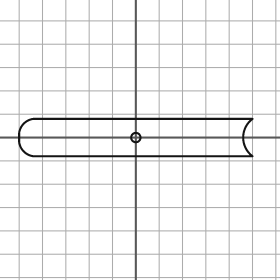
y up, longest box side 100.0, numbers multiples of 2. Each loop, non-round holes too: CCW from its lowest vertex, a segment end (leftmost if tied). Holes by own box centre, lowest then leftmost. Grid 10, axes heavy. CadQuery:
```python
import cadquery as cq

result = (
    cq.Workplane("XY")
    .moveTo(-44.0, -8.0)
    .lineTo(50.0, -8.0)
    .threePointArc((46.0, 0.0), (50.0, 8.0))
    .lineTo(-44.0, 8.0)
    .threePointArc((-48.0, 6.0), (-50.0, 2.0))
    .lineTo(-50.0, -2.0)
    .threePointArc((-48.0, -6.0), (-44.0, -8.0))
    .close()
    .moveTo(0.0, 0.0)
    .circle(2.0)
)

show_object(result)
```